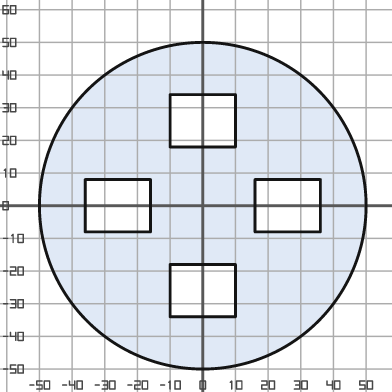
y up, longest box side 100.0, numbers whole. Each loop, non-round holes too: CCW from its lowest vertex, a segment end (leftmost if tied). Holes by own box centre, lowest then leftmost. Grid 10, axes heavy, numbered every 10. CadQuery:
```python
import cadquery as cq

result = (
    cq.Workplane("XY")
    .moveTo(0.0, 0.0)
    .circle(50.0)
    .moveTo(-10.0, -34.0)
    .lineTo(10.0, -34.0)
    .lineTo(10.0, -18.0)
    .lineTo(-10.0, -18.0)
    .close()
    .moveTo(-36.0, -8.0)
    .lineTo(-16.0, -8.0)
    .lineTo(-16.0, 8.0)
    .lineTo(-36.0, 8.0)
    .close()
    .moveTo(16.0, -8.0)
    .lineTo(36.0, -8.0)
    .lineTo(36.0, 8.0)
    .lineTo(16.0, 8.0)
    .close()
    .moveTo(-10.0, 18.0)
    .lineTo(10.0, 18.0)
    .lineTo(10.0, 34.0)
    .lineTo(-10.0, 34.0)
    .close()
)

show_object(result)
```